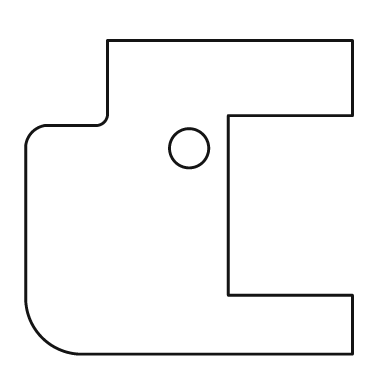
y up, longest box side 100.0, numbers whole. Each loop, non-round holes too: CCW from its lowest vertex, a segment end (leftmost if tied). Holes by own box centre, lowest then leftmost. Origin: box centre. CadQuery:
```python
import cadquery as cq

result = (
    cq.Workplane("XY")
    .moveTo(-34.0, -48.0)
    .lineTo(50.0, -48.0)
    .lineTo(50.0, -30.0)
    .lineTo(12.0, -30.0)
    .lineTo(12.0, 25.0)
    .lineTo(50.0, 25.0)
    .lineTo(50.0, 48.0)
    .lineTo(-25.0, 48.0)
    .lineTo(-25.0, 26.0)
    .threePointArc((-26.0, 23.0), (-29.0, 22.0))
    .lineTo(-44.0, 22.0)
    .threePointArc((-48.0, 20.0), (-50.0, 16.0))
    .lineTo(-50.0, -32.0)
    .threePointArc((-45.0, -43.0), (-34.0, -48.0))
    .close()
    .moveTo(0.0, 15.0)
    .circle(6.0)
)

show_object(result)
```